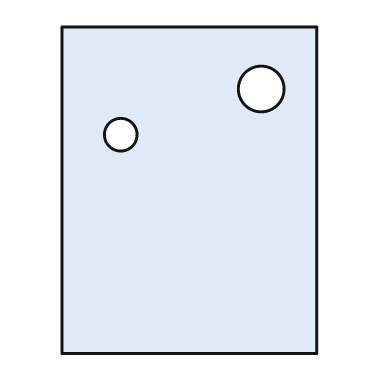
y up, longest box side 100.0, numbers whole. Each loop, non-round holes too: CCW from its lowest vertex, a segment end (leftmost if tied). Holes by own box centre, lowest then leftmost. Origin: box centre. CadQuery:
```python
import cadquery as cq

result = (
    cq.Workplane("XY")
    .moveTo(-39.0, -50.0)
    .lineTo(39.0, -50.0)
    .lineTo(39.0, 50.0)
    .lineTo(-39.0, 50.0)
    .close()
    .moveTo(-21.0, 17.0)
    .circle(5.0)
    .moveTo(22.0, 31.0)
    .circle(7.0)
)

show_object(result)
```